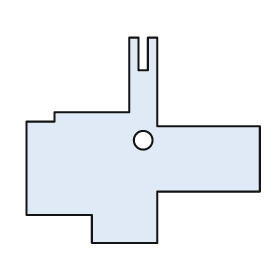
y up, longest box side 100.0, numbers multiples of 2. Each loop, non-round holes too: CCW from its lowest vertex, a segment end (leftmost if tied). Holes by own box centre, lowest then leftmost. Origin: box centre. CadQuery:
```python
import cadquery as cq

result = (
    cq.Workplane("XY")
    .moveTo(-22.0, -44.0)
    .lineTo(6.0, -44.0)
    .lineTo(6.0, -22.0)
    .lineTo(50.0, -22.0)
    .lineTo(50.0, 6.0)
    .lineTo(6.0, 6.0)
    .lineTo(6.0, 44.0)
    .lineTo(2.0, 44.0)
    .lineTo(2.0, 30.0)
    .lineTo(-2.0, 30.0)
    .lineTo(-2.0, 44.0)
    .lineTo(-6.0, 44.0)
    .lineTo(-6.0, 12.0)
    .lineTo(-38.0, 12.0)
    .lineTo(-38.0, 8.0)
    .lineTo(-50.0, 8.0)
    .lineTo(-50.0, -32.0)
    .lineTo(-22.0, -32.0)
    .close()
    .moveTo(0.0, 0.0)
    .circle(4.0)
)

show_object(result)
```